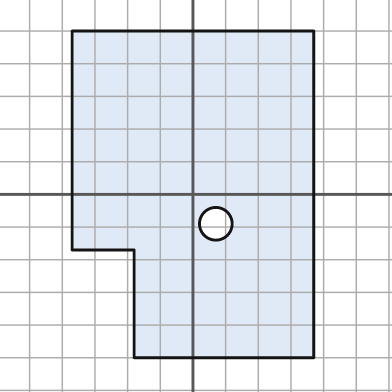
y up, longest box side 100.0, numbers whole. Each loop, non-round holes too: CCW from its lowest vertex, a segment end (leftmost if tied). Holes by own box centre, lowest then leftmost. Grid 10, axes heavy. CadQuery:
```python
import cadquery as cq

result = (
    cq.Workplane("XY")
    .moveTo(-18.0, -50.0)
    .lineTo(37.0, -50.0)
    .lineTo(37.0, 50.0)
    .lineTo(-37.0, 50.0)
    .lineTo(-37.0, -17.0)
    .lineTo(-18.0, -17.0)
    .close()
    .moveTo(7.0, -9.0)
    .circle(5.0)
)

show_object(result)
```